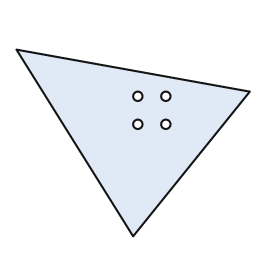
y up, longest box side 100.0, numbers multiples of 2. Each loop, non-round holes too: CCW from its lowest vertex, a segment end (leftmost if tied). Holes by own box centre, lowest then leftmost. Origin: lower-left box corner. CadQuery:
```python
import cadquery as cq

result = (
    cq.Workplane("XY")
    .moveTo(50.0, 0.0)
    .lineTo(100.0, 62.0)
    .lineTo(0.0, 80.0)
    .close()
    .moveTo(52.0, 48.0)
    .circle(2.0)
    .moveTo(64.0, 48.0)
    .circle(2.0)
    .moveTo(52.0, 60.0)
    .circle(2.0)
    .moveTo(64.0, 60.0)
    .circle(2.0)
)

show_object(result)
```